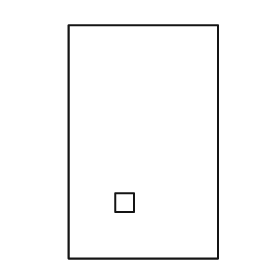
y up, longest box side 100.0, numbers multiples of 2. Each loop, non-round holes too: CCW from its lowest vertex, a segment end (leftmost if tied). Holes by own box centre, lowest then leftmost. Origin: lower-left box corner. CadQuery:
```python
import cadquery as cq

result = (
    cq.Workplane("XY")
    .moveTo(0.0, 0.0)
    .lineTo(64.0, 0.0)
    .lineTo(64.0, 100.0)
    .lineTo(0.0, 100.0)
    .close()
    .moveTo(20.0, 20.0)
    .lineTo(28.0, 20.0)
    .lineTo(28.0, 28.0)
    .lineTo(20.0, 28.0)
    .close()
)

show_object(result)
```